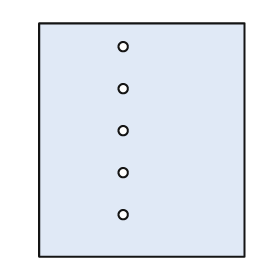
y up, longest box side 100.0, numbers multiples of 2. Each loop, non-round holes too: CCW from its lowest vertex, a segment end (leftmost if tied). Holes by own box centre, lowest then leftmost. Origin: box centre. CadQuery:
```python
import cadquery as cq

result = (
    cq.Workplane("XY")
    .moveTo(-44.0, -50.0)
    .lineTo(44.0, -50.0)
    .lineTo(44.0, 50.0)
    .lineTo(-44.0, 50.0)
    .close()
    .moveTo(-8.0, -32.0)
    .circle(2.0)
    .moveTo(-8.0, -14.0)
    .circle(2.0)
    .moveTo(-8.0, 4.0)
    .circle(2.0)
    .moveTo(-8.0, 22.0)
    .circle(2.0)
    .moveTo(-8.0, 40.0)
    .circle(2.0)
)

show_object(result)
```